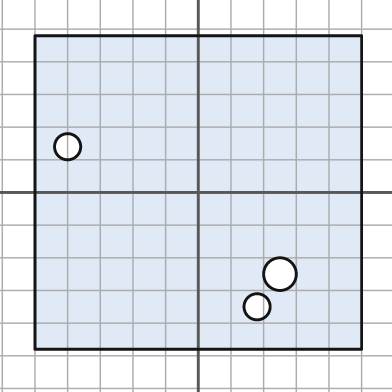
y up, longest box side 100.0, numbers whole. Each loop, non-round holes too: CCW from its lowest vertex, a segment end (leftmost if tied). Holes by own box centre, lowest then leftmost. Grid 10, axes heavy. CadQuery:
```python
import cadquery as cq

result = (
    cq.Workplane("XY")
    .moveTo(-50.0, -48.0)
    .lineTo(50.0, -48.0)
    .lineTo(50.0, 48.0)
    .lineTo(-50.0, 48.0)
    .close()
    .moveTo(18.0, -35.0)
    .circle(4.0)
    .moveTo(25.0, -25.0)
    .circle(5.0)
    .moveTo(-40.0, 14.0)
    .circle(4.0)
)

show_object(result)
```